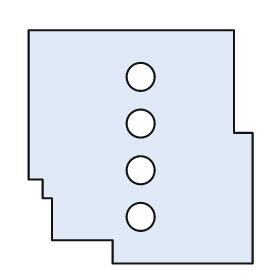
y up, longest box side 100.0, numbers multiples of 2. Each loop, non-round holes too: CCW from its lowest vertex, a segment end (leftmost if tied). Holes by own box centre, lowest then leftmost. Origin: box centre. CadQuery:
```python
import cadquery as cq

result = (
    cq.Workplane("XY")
    .moveTo(-12.0, -50.0)
    .lineTo(48.0, -50.0)
    .lineTo(48.0, 6.0)
    .lineTo(40.0, 6.0)
    .lineTo(40.0, 50.0)
    .lineTo(-48.0, 50.0)
    .lineTo(-48.0, -14.0)
    .lineTo(-42.0, -14.0)
    .lineTo(-42.0, -22.0)
    .lineTo(-38.0, -22.0)
    .lineTo(-38.0, -40.0)
    .lineTo(-12.0, -40.0)
    .close()
    .moveTo(0.0, -30.0)
    .circle(6.0)
    .moveTo(0.0, -10.0)
    .circle(6.0)
    .moveTo(0.0, 10.0)
    .circle(6.0)
    .moveTo(0.0, 30.0)
    .circle(6.0)
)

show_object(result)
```